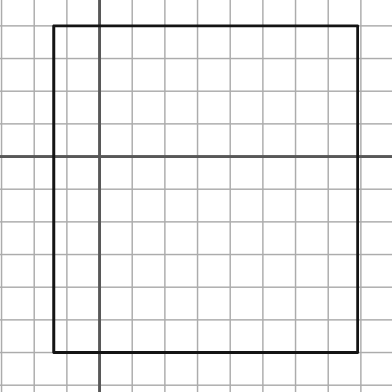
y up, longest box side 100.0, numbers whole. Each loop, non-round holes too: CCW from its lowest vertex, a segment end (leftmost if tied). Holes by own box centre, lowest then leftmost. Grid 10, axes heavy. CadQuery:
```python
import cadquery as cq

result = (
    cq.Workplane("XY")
    .moveTo(-14.0, -60.0)
    .lineTo(79.0, -60.0)
    .lineTo(79.0, 40.0)
    .lineTo(-14.0, 40.0)
    .close()
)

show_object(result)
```